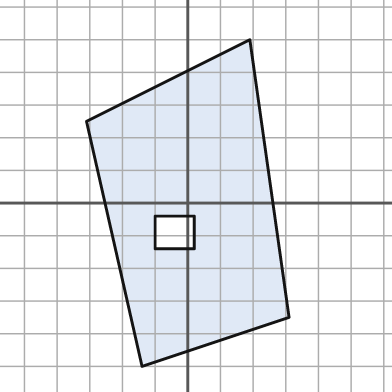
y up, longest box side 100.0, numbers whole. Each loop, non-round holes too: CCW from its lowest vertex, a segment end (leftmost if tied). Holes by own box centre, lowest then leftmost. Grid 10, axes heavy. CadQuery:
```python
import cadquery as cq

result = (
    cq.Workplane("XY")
    .moveTo(-14.0, -50.0)
    .lineTo(31.0, -35.0)
    .lineTo(19.0, 50.0)
    .lineTo(-31.0, 25.0)
    .close()
    .moveTo(-10.0, -14.0)
    .lineTo(2.0, -14.0)
    .lineTo(2.0, -4.0)
    .lineTo(-10.0, -4.0)
    .close()
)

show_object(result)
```